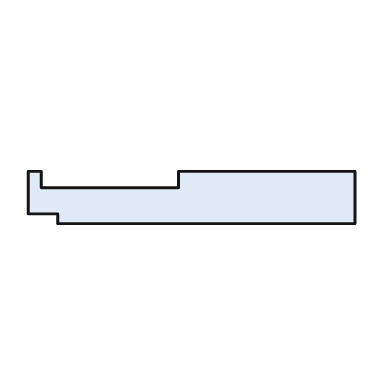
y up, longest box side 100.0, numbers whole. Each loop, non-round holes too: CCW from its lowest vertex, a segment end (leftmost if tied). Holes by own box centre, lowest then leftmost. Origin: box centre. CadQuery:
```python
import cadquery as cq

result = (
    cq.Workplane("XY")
    .moveTo(-41.0, -8.0)
    .lineTo(50.0, -8.0)
    .lineTo(50.0, 8.0)
    .lineTo(-4.0, 8.0)
    .lineTo(-4.0, 3.0)
    .lineTo(-46.0, 3.0)
    .lineTo(-46.0, 8.0)
    .lineTo(-50.0, 8.0)
    .lineTo(-50.0, -5.0)
    .lineTo(-41.0, -5.0)
    .close()
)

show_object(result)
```